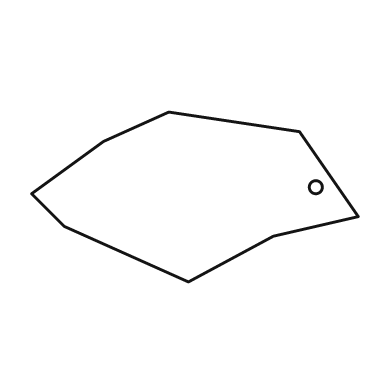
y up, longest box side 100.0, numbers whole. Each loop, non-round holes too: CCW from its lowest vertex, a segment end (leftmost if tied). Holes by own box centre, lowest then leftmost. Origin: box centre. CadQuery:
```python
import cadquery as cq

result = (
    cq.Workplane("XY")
    .moveTo(-2.0, -26.0)
    .lineTo(24.0, -12.0)
    .lineTo(50.0, -6.0)
    .lineTo(32.0, 20.0)
    .lineTo(-8.0, 26.0)
    .lineTo(-28.0, 17.0)
    .lineTo(-50.0, 1.0)
    .lineTo(-40.0, -9.0)
    .close()
    .moveTo(37.0, 3.0)
    .circle(2.0)
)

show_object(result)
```